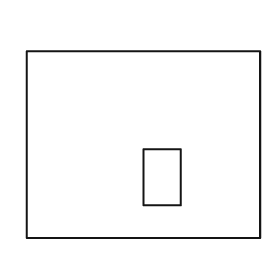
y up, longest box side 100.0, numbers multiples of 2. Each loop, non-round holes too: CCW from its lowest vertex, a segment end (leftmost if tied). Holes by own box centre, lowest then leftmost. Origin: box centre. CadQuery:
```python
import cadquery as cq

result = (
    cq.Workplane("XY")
    .moveTo(-50.0, -40.0)
    .lineTo(50.0, -40.0)
    .lineTo(50.0, 40.0)
    .lineTo(-50.0, 40.0)
    .close()
    .moveTo(0.0, -26.0)
    .lineTo(16.0, -26.0)
    .lineTo(16.0, -2.0)
    .lineTo(0.0, -2.0)
    .close()
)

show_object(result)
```